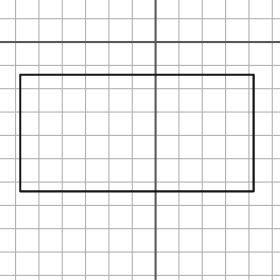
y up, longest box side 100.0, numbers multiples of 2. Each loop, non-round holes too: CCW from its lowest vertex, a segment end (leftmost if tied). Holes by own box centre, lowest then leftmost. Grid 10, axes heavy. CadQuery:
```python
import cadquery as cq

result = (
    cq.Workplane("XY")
    .moveTo(-58.0, -64.0)
    .lineTo(42.0, -64.0)
    .lineTo(42.0, -14.0)
    .lineTo(-58.0, -14.0)
    .close()
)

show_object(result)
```